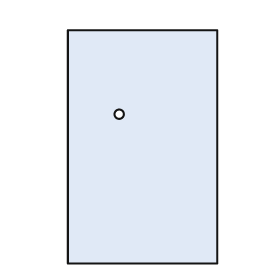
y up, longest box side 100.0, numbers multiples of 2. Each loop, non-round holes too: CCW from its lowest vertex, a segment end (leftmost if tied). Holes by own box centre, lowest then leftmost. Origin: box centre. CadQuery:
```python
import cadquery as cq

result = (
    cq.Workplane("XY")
    .moveTo(-32.0, -50.0)
    .lineTo(32.0, -50.0)
    .lineTo(32.0, 50.0)
    .lineTo(-32.0, 50.0)
    .close()
    .moveTo(-10.0, 14.0)
    .circle(2.0)
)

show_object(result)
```